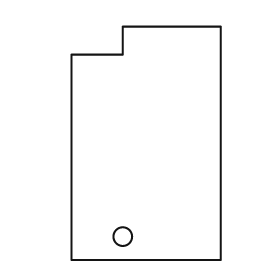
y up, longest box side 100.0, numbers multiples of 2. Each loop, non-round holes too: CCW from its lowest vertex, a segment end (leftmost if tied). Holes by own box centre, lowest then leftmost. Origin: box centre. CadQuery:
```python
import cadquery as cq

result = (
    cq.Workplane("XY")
    .moveTo(-32.0, -50.0)
    .lineTo(32.0, -50.0)
    .lineTo(32.0, 50.0)
    .lineTo(-10.0, 50.0)
    .lineTo(-10.0, 38.0)
    .lineTo(-32.0, 38.0)
    .close()
    .moveTo(-10.0, -40.0)
    .circle(4.0)
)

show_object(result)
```